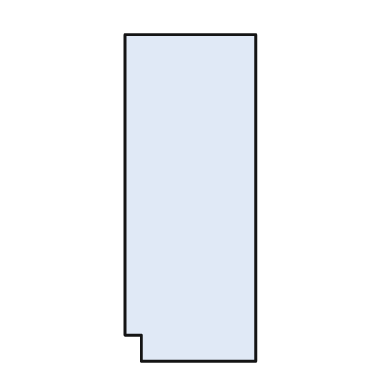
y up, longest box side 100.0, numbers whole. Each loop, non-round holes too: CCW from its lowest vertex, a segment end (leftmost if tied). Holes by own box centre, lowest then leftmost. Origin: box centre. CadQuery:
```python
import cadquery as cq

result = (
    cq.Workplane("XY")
    .moveTo(-15.0, -50.0)
    .lineTo(20.0, -50.0)
    .lineTo(20.0, 50.0)
    .lineTo(-20.0, 50.0)
    .lineTo(-20.0, -42.0)
    .lineTo(-15.0, -42.0)
    .close()
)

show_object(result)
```